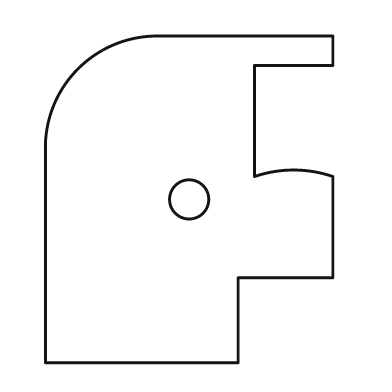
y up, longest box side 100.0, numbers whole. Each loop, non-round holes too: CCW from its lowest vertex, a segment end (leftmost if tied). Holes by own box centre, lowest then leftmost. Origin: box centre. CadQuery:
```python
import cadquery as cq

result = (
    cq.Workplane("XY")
    .moveTo(-44.0, -50.0)
    .lineTo(15.0, -50.0)
    .lineTo(15.0, -24.0)
    .lineTo(44.0, -24.0)
    .lineTo(44.0, 7.0)
    .threePointArc((32.0, 9.0), (20.0, 7.0))
    .lineTo(20.0, 41.0)
    .lineTo(44.0, 41.0)
    .lineTo(44.0, 50.0)
    .lineTo(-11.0, 50.0)
    .threePointArc((-34.0, 40.0), (-44.0, 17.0))
    .close()
    .moveTo(0.0, 0.0)
    .circle(6.0)
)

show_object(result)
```